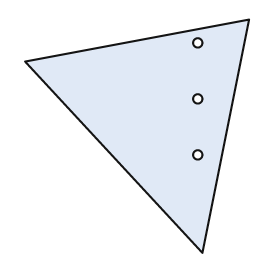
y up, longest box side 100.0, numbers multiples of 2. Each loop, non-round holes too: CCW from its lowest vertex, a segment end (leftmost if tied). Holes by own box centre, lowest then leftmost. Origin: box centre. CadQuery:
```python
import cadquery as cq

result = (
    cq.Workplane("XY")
    .moveTo(28.0, -50.0)
    .lineTo(48.0, 50.0)
    .lineTo(-48.0, 32.0)
    .close()
    .moveTo(26.0, -8.0)
    .circle(2.0)
    .moveTo(26.0, 16.0)
    .circle(2.0)
    .moveTo(26.0, 40.0)
    .circle(2.0)
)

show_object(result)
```